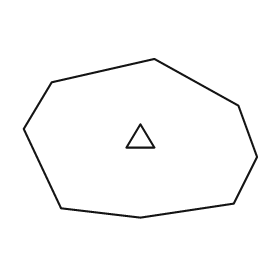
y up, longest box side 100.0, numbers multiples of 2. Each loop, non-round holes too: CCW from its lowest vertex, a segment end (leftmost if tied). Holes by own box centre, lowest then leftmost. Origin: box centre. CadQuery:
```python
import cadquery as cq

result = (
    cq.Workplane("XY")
    .moveTo(0.0, -34.0)
    .lineTo(40.0, -28.0)
    .lineTo(50.0, -8.0)
    .lineTo(42.0, 14.0)
    .lineTo(6.0, 34.0)
    .lineTo(-38.0, 24.0)
    .lineTo(-50.0, 4.0)
    .lineTo(-34.0, -30.0)
    .close()
    .moveTo(-6.0, -4.0)
    .lineTo(6.0, -4.0)
    .lineTo(0.0, 6.0)
    .close()
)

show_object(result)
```